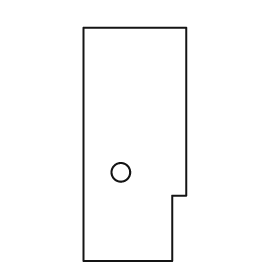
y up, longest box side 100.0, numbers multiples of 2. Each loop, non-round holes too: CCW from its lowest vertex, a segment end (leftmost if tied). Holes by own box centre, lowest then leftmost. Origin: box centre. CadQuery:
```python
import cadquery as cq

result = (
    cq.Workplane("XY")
    .moveTo(-22.0, -50.0)
    .lineTo(16.0, -50.0)
    .lineTo(16.0, -22.0)
    .lineTo(22.0, -22.0)
    .lineTo(22.0, 50.0)
    .lineTo(-22.0, 50.0)
    .close()
    .moveTo(-6.0, -12.0)
    .circle(4.0)
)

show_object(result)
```